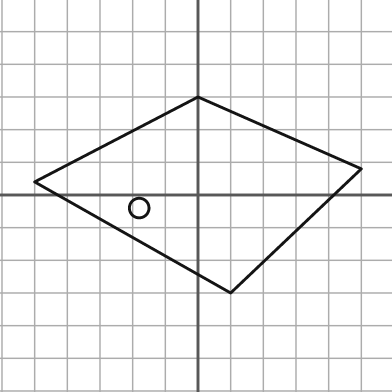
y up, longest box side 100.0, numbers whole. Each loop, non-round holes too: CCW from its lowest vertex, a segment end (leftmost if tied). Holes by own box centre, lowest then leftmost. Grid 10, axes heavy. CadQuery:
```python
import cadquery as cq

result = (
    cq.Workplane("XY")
    .moveTo(10.0, -30.0)
    .lineTo(50.0, 8.0)
    .lineTo(0.0, 30.0)
    .lineTo(-50.0, 4.0)
    .close()
    .moveTo(-18.0, -4.0)
    .circle(3.0)
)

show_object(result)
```